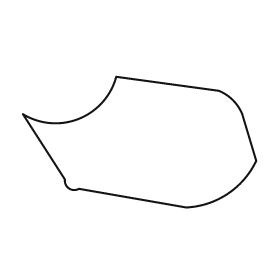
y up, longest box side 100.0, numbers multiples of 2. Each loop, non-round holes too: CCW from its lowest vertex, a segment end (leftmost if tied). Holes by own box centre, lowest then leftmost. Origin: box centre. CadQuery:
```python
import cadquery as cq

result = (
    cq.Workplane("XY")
    .moveTo(20.0, -28.0)
    .threePointArc((38.0, -22.0), (50.0, -8.0))
    .lineTo(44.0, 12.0)
    .threePointArc((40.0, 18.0), (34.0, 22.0))
    .lineTo(-10.0, 28.0)
    .threePointArc((-26.0, 10.0), (-50.0, 12.0))
    .lineTo(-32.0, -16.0)
    .threePointArc((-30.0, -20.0), (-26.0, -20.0))
    .close()
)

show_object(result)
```